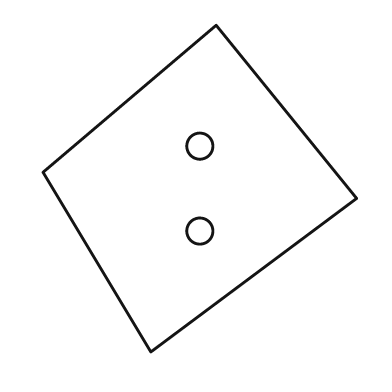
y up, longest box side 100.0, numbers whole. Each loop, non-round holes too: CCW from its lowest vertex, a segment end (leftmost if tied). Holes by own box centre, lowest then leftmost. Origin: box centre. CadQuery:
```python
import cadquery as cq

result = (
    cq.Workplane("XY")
    .moveTo(-15.0, -50.0)
    .lineTo(48.0, -3.0)
    .lineTo(5.0, 50.0)
    .lineTo(-48.0, 5.0)
    .close()
    .moveTo(0.0, -13.0)
    .circle(4.0)
    .moveTo(0.0, 13.0)
    .circle(4.0)
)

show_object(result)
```